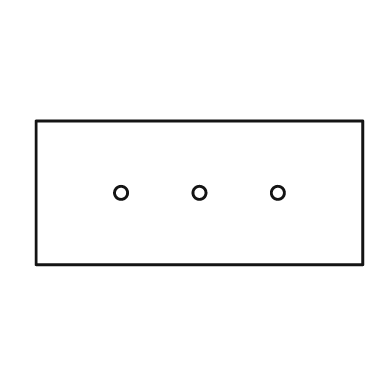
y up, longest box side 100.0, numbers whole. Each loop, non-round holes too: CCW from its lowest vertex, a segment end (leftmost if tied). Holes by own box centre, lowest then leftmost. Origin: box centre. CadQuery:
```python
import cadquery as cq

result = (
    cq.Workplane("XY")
    .moveTo(-50.0, -22.0)
    .lineTo(50.0, -22.0)
    .lineTo(50.0, 22.0)
    .lineTo(-50.0, 22.0)
    .close()
    .moveTo(-24.0, 0.0)
    .circle(2.0)
    .moveTo(0.0, 0.0)
    .circle(2.0)
    .moveTo(24.0, 0.0)
    .circle(2.0)
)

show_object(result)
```